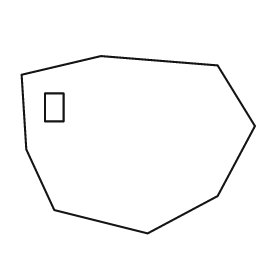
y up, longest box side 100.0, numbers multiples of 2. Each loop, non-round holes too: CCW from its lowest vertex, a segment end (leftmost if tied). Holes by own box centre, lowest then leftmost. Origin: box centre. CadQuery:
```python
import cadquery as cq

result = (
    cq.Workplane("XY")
    .moveTo(4.0, -38.0)
    .lineTo(34.0, -22.0)
    .lineTo(50.0, 8.0)
    .lineTo(34.0, 34.0)
    .lineTo(-16.0, 38.0)
    .lineTo(-50.0, 30.0)
    .lineTo(-48.0, -2.0)
    .lineTo(-36.0, -28.0)
    .close()
    .moveTo(-40.0, 10.0)
    .lineTo(-32.0, 10.0)
    .lineTo(-32.0, 22.0)
    .lineTo(-40.0, 22.0)
    .close()
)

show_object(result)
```